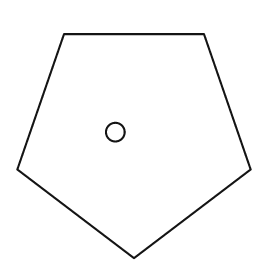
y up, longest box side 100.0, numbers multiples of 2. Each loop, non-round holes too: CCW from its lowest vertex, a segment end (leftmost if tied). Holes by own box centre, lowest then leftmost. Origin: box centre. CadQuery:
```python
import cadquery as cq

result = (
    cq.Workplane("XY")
    .moveTo(0.0, -48.0)
    .lineTo(50.0, -10.0)
    .lineTo(30.0, 48.0)
    .lineTo(-30.0, 48.0)
    .lineTo(-50.0, -10.0)
    .close()
    .moveTo(-8.0, 6.0)
    .circle(4.0)
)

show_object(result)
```